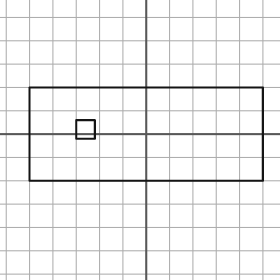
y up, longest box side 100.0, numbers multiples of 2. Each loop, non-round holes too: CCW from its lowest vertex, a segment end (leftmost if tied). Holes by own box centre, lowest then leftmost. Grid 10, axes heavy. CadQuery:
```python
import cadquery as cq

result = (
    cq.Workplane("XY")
    .moveTo(-50.0, -20.0)
    .lineTo(50.0, -20.0)
    .lineTo(50.0, 20.0)
    .lineTo(-50.0, 20.0)
    .close()
    .moveTo(-30.0, -2.0)
    .lineTo(-22.0, -2.0)
    .lineTo(-22.0, 6.0)
    .lineTo(-30.0, 6.0)
    .close()
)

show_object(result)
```